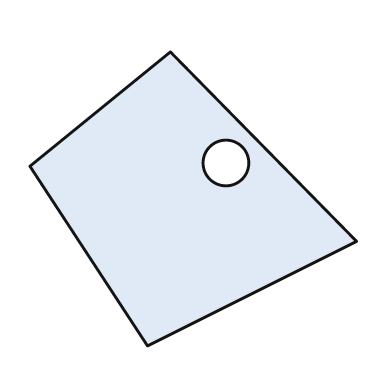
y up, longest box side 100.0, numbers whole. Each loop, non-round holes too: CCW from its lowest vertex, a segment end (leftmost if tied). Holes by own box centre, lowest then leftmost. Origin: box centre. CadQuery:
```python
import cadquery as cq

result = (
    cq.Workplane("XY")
    .moveTo(-14.0, -45.0)
    .lineTo(50.0, -13.0)
    .lineTo(-7.0, 45.0)
    .lineTo(-50.0, 10.0)
    .close()
    .moveTo(10.0, 11.0)
    .circle(7.0)
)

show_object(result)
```